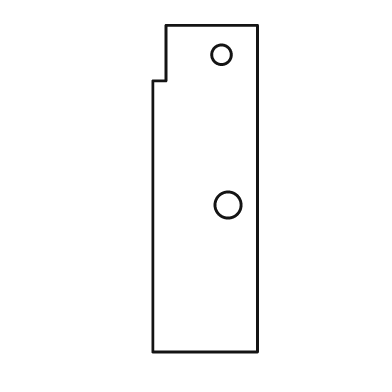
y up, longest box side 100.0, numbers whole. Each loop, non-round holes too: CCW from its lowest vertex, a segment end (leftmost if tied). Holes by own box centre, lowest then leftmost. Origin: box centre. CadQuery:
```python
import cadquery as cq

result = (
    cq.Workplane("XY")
    .moveTo(-16.0, -50.0)
    .lineTo(16.0, -50.0)
    .lineTo(16.0, 50.0)
    .lineTo(-12.0, 50.0)
    .lineTo(-12.0, 33.0)
    .lineTo(-16.0, 33.0)
    .close()
    .moveTo(7.0, -5.0)
    .circle(4.0)
    .moveTo(5.0, 41.0)
    .circle(3.0)
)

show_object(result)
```